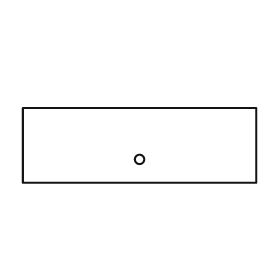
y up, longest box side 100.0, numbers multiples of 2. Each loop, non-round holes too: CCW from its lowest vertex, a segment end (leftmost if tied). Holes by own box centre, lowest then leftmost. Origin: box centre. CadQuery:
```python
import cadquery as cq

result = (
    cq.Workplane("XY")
    .moveTo(-50.0, -16.0)
    .lineTo(50.0, -16.0)
    .lineTo(50.0, 16.0)
    .lineTo(-50.0, 16.0)
    .close()
    .moveTo(0.0, -6.0)
    .circle(2.0)
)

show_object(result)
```